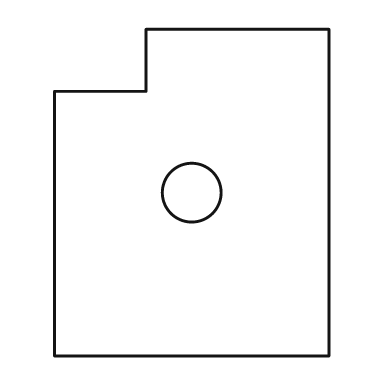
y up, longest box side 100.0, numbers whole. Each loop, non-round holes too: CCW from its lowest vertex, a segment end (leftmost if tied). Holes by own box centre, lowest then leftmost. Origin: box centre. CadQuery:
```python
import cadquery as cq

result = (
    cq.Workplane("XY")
    .moveTo(-42.0, -50.0)
    .lineTo(42.0, -50.0)
    .lineTo(42.0, 50.0)
    .lineTo(-14.0, 50.0)
    .lineTo(-14.0, 31.0)
    .lineTo(-42.0, 31.0)
    .close()
    .moveTo(0.0, 0.0)
    .circle(9.0)
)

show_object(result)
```